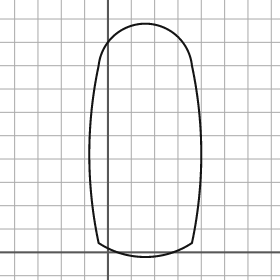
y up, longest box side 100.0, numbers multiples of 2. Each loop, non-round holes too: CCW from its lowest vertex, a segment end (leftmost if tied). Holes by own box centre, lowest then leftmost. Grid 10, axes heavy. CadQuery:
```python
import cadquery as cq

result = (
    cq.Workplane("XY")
    .moveTo(-4.0, 4.0)
    .threePointArc((16.0, -2.0), (36.0, 4.0))
    .threePointArc((40.0, 42.0), (36.0, 80.0))
    .threePointArc((16.0, 98.0), (-4.0, 80.0))
    .threePointArc((-8.0, 42.0), (-4.0, 4.0))
    .close()
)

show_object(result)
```